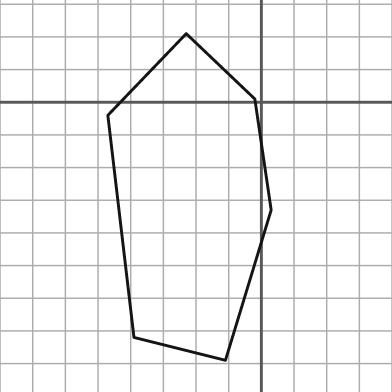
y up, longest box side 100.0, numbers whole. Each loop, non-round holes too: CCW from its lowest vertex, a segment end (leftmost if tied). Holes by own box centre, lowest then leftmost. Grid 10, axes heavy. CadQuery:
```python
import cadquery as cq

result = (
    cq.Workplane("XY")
    .moveTo(-11.0, -79.0)
    .lineTo(3.0, -33.0)
    .lineTo(-2.0, 1.0)
    .lineTo(-23.0, 21.0)
    .lineTo(-47.0, -4.0)
    .lineTo(-39.0, -72.0)
    .close()
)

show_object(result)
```